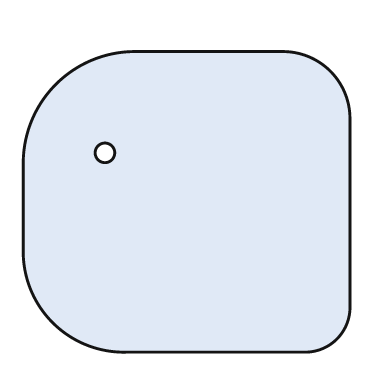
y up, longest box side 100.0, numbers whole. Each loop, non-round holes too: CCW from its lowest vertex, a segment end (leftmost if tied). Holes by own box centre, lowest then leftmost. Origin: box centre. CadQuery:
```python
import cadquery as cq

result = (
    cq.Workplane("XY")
    .moveTo(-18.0, -46.0)
    .lineTo(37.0, -46.0)
    .threePointArc((46.0, -42.0), (50.0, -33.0))
    .lineTo(50.0, 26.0)
    .threePointArc((44.0, 40.0), (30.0, 46.0))
    .lineTo(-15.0, 46.0)
    .threePointArc((-40.0, 36.0), (-50.0, 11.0))
    .lineTo(-50.0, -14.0)
    .threePointArc((-41.0, -37.0), (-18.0, -46.0))
    .close()
    .moveTo(-25.0, 15.0)
    .circle(3.0)
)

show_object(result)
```